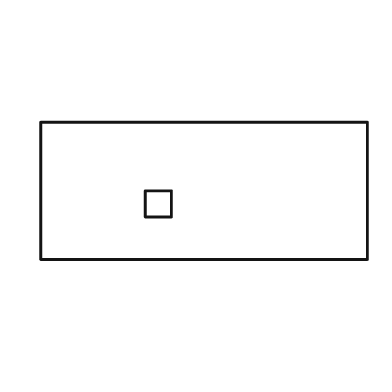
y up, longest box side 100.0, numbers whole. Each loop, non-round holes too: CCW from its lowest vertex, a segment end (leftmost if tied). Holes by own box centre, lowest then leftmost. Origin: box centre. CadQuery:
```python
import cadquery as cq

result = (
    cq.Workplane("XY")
    .moveTo(-50.0, -21.0)
    .lineTo(50.0, -21.0)
    .lineTo(50.0, 21.0)
    .lineTo(-50.0, 21.0)
    .close()
    .moveTo(-18.0, -8.0)
    .lineTo(-10.0, -8.0)
    .lineTo(-10.0, 0.0)
    .lineTo(-18.0, 0.0)
    .close()
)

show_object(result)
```